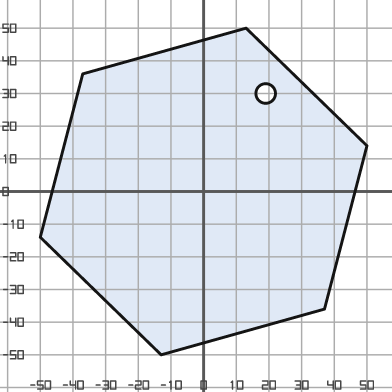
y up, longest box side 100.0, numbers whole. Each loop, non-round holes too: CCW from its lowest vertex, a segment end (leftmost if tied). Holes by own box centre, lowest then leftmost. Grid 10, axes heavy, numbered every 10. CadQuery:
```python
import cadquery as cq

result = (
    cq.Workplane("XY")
    .moveTo(-13.0, -50.0)
    .lineTo(37.0, -36.0)
    .lineTo(50.0, 14.0)
    .lineTo(13.0, 50.0)
    .lineTo(-37.0, 36.0)
    .lineTo(-50.0, -14.0)
    .close()
    .moveTo(19.0, 30.0)
    .circle(3.0)
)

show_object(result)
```